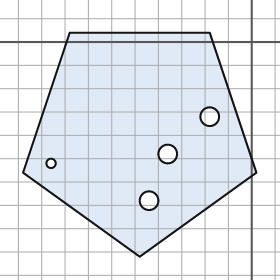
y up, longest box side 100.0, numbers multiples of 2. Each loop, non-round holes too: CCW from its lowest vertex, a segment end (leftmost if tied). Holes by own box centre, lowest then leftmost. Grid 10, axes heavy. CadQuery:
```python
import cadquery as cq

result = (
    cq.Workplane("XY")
    .moveTo(-48.0, -92.0)
    .lineTo(2.0, -56.0)
    .lineTo(-18.0, 4.0)
    .lineTo(-78.0, 4.0)
    .lineTo(-98.0, -56.0)
    .close()
    .moveTo(-44.0, -68.0)
    .circle(4.0)
    .moveTo(-86.0, -52.0)
    .circle(2.0)
    .moveTo(-36.0, -48.0)
    .circle(4.0)
    .moveTo(-18.0, -32.0)
    .circle(4.0)
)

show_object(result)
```